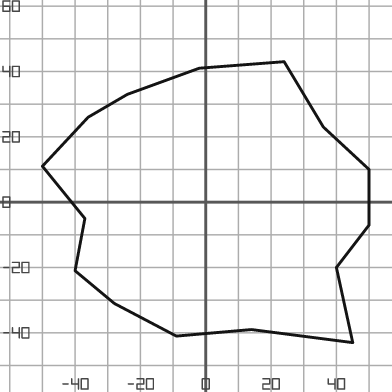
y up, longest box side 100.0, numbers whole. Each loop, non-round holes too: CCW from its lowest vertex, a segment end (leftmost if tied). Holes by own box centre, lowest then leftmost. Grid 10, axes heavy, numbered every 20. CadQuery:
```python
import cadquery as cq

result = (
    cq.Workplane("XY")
    .moveTo(45.0, -43.0)
    .lineTo(40.0, -20.0)
    .lineTo(50.0, -7.0)
    .lineTo(50.0, 10.0)
    .lineTo(36.0, 23.0)
    .lineTo(24.0, 43.0)
    .lineTo(-2.0, 41.0)
    .lineTo(-24.0, 33.0)
    .lineTo(-36.0, 26.0)
    .lineTo(-50.0, 11.0)
    .lineTo(-37.0, -5.0)
    .lineTo(-40.0, -21.0)
    .lineTo(-28.0, -31.0)
    .lineTo(-9.0, -41.0)
    .lineTo(14.0, -39.0)
    .close()
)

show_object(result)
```